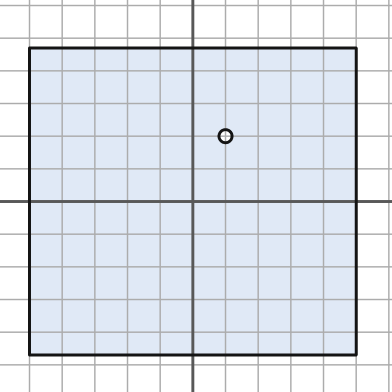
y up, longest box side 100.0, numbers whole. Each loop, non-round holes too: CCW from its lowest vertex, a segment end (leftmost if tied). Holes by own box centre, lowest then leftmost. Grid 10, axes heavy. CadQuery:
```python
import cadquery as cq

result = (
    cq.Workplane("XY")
    .moveTo(-50.0, -47.0)
    .lineTo(50.0, -47.0)
    .lineTo(50.0, 47.0)
    .lineTo(-50.0, 47.0)
    .close()
    .moveTo(10.0, 20.0)
    .circle(2.0)
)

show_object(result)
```